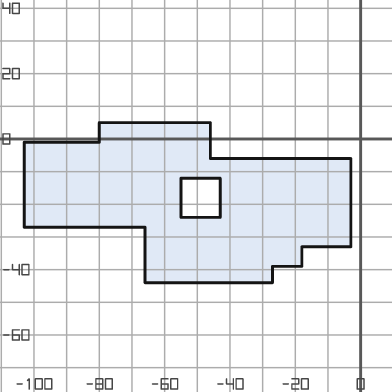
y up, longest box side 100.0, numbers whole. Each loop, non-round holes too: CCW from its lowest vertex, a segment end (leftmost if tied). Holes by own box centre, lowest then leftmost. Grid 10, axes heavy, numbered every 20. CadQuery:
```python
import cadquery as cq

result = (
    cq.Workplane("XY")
    .moveTo(-66.0, -44.0)
    .lineTo(-27.0, -44.0)
    .lineTo(-27.0, -39.0)
    .lineTo(-18.0, -39.0)
    .lineTo(-18.0, -33.0)
    .lineTo(-3.0, -33.0)
    .lineTo(-3.0, -6.0)
    .lineTo(-46.0, -6.0)
    .lineTo(-46.0, 5.0)
    .lineTo(-80.0, 5.0)
    .lineTo(-80.0, -1.0)
    .lineTo(-103.0, -1.0)
    .lineTo(-103.0, -27.0)
    .lineTo(-66.0, -27.0)
    .close()
    .moveTo(-55.0, -24.0)
    .lineTo(-43.0, -24.0)
    .lineTo(-43.0, -12.0)
    .lineTo(-55.0, -12.0)
    .close()
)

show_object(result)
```